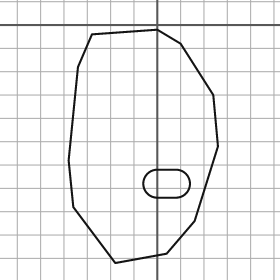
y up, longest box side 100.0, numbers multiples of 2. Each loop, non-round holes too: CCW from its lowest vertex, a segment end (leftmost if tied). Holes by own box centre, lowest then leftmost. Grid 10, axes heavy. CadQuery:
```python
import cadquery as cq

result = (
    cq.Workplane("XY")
    .moveTo(-18.0, -102.0)
    .lineTo(4.0, -98.0)
    .lineTo(16.0, -84.0)
    .lineTo(26.0, -52.0)
    .lineTo(24.0, -30.0)
    .lineTo(10.0, -8.0)
    .lineTo(0.0, -2.0)
    .lineTo(-28.0, -4.0)
    .lineTo(-34.0, -18.0)
    .lineTo(-38.0, -58.0)
    .lineTo(-36.0, -78.0)
    .close()
    .moveTo(0.0, -74.0)
    .lineTo(8.0, -74.0)
    .threePointArc((14.0, -68.0), (8.0, -62.0))
    .lineTo(0.0, -62.0)
    .threePointArc((-6.0, -68.0), (0.0, -74.0))
    .close()
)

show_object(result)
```